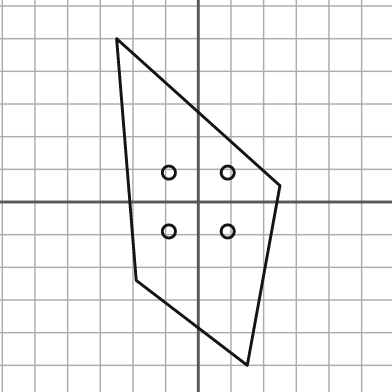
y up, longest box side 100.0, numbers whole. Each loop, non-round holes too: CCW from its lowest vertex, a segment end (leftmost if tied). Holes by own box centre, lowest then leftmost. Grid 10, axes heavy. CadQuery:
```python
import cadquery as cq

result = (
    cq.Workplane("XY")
    .moveTo(15.0, -50.0)
    .lineTo(25.0, 5.0)
    .lineTo(-25.0, 50.0)
    .lineTo(-19.0, -24.0)
    .close()
    .moveTo(-9.0, -9.0)
    .circle(2.0)
    .moveTo(9.0, -9.0)
    .circle(2.0)
    .moveTo(-9.0, 9.0)
    .circle(2.0)
    .moveTo(9.0, 9.0)
    .circle(2.0)
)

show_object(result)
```